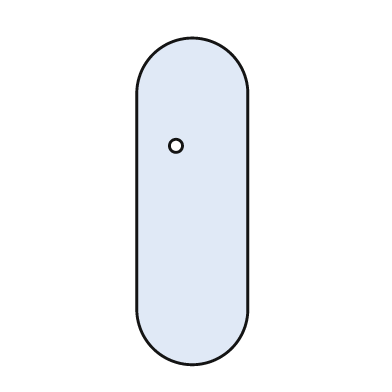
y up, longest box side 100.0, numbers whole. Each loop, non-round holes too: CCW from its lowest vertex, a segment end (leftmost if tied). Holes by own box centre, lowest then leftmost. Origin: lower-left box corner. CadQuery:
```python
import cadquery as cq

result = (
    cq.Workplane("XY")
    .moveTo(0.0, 17.0)
    .threePointArc((17.0, 0.0), (34.0, 17.0))
    .lineTo(34.0, 83.0)
    .threePointArc((17.0, 100.0), (0.0, 83.0))
    .close()
    .moveTo(12.0, 67.0)
    .circle(2.0)
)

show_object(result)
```